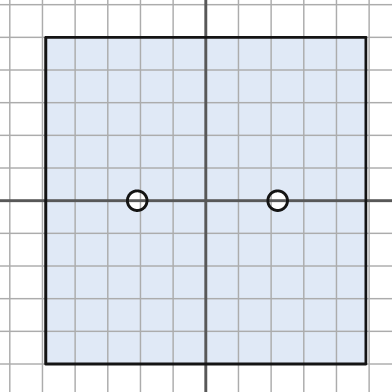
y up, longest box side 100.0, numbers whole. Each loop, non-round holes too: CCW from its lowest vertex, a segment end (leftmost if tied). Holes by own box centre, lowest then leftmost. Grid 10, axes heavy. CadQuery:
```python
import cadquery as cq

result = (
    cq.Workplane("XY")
    .moveTo(-49.0, -50.0)
    .lineTo(49.0, -50.0)
    .lineTo(49.0, 50.0)
    .lineTo(-49.0, 50.0)
    .close()
    .moveTo(-21.0, 0.0)
    .circle(3.0)
    .moveTo(22.0, 0.0)
    .circle(3.0)
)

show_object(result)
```